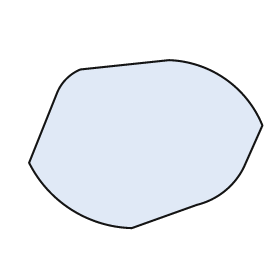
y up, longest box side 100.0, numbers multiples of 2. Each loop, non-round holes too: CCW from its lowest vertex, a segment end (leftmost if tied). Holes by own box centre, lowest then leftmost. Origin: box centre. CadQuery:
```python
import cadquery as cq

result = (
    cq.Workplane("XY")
    .moveTo(-6.0, -36.0)
    .lineTo(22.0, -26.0)
    .threePointArc((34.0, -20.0), (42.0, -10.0))
    .lineTo(50.0, 8.0)
    .threePointArc((34.0, 28.0), (10.0, 36.0))
    .lineTo(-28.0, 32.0)
    .threePointArc((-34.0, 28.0), (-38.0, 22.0))
    .lineTo(-50.0, -8.0)
    .threePointArc((-32.0, -28.0), (-6.0, -36.0))
    .close()
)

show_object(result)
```